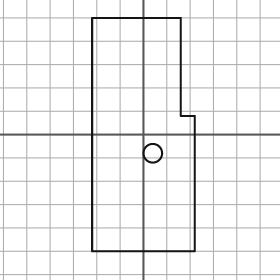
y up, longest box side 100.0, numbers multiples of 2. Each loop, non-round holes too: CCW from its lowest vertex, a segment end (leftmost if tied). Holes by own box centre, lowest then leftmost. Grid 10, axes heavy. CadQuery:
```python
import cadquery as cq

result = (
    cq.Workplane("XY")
    .moveTo(-22.0, -50.0)
    .lineTo(22.0, -50.0)
    .lineTo(22.0, 8.0)
    .lineTo(16.0, 8.0)
    .lineTo(16.0, 50.0)
    .lineTo(-22.0, 50.0)
    .close()
    .moveTo(4.0, -8.0)
    .circle(4.0)
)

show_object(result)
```